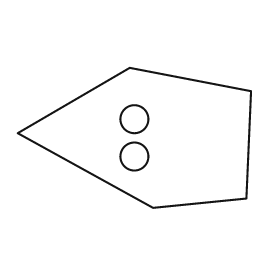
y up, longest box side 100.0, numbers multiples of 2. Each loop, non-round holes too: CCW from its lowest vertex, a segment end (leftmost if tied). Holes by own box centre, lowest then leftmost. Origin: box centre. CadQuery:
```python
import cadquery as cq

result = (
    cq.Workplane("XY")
    .moveTo(8.0, -30.0)
    .lineTo(48.0, -26.0)
    .lineTo(50.0, 20.0)
    .lineTo(-2.0, 30.0)
    .lineTo(-50.0, 2.0)
    .close()
    .moveTo(0.0, -8.0)
    .circle(6.0)
    .moveTo(0.0, 8.0)
    .circle(6.0)
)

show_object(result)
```